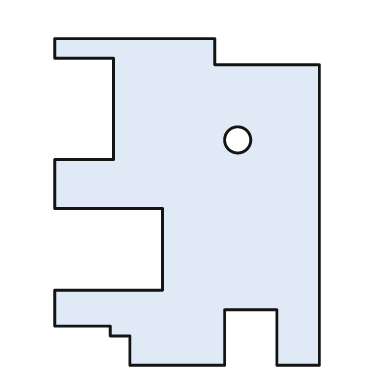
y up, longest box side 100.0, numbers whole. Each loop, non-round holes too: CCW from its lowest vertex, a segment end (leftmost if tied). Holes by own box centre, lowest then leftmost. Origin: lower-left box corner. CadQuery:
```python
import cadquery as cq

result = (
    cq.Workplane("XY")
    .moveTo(23.0, 0.0)
    .lineTo(52.0, 0.0)
    .lineTo(52.0, 17.0)
    .lineTo(68.0, 17.0)
    .lineTo(68.0, 0.0)
    .lineTo(81.0, 0.0)
    .lineTo(81.0, 92.0)
    .lineTo(49.0, 92.0)
    .lineTo(49.0, 100.0)
    .lineTo(0.0, 100.0)
    .lineTo(0.0, 94.0)
    .lineTo(18.0, 94.0)
    .lineTo(18.0, 63.0)
    .lineTo(0.0, 63.0)
    .lineTo(0.0, 48.0)
    .lineTo(33.0, 48.0)
    .lineTo(33.0, 23.0)
    .lineTo(0.0, 23.0)
    .lineTo(0.0, 12.0)
    .lineTo(17.0, 12.0)
    .lineTo(17.0, 9.0)
    .lineTo(23.0, 9.0)
    .close()
    .moveTo(56.0, 69.0)
    .circle(4.0)
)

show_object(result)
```